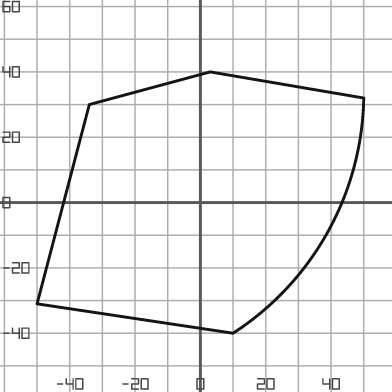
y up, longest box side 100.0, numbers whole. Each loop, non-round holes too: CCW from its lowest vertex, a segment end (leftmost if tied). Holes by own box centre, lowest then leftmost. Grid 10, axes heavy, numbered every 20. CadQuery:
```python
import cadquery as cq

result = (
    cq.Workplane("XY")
    .moveTo(10.0, -40.0)
    .threePointArc((39.0, -9.0), (50.0, 32.0))
    .lineTo(3.0, 40.0)
    .lineTo(-34.0, 30.0)
    .lineTo(-50.0, -31.0)
    .close()
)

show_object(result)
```